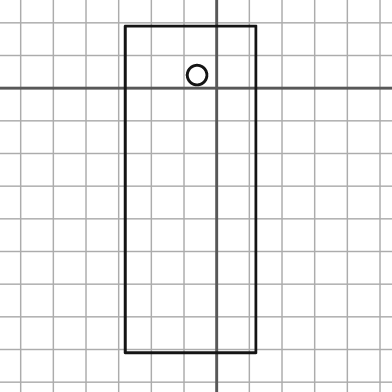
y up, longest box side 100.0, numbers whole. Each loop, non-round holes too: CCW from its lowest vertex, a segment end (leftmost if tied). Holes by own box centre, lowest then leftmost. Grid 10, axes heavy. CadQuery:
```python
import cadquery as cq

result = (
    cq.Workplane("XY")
    .moveTo(-28.0, -81.0)
    .lineTo(12.0, -81.0)
    .lineTo(12.0, 19.0)
    .lineTo(-28.0, 19.0)
    .close()
    .moveTo(-6.0, 4.0)
    .circle(3.0)
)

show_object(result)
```